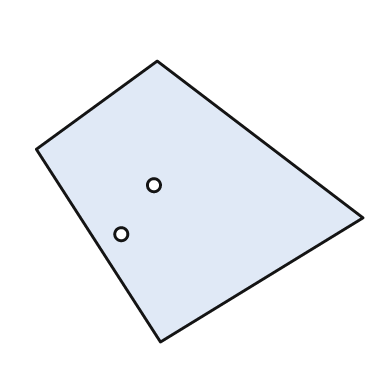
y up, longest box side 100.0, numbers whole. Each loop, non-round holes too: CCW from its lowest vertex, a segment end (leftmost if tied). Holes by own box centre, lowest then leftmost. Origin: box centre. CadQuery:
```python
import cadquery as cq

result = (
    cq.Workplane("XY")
    .moveTo(-12.0, -43.0)
    .lineTo(50.0, -5.0)
    .lineTo(-13.0, 43.0)
    .lineTo(-50.0, 16.0)
    .close()
    .moveTo(-24.0, -10.0)
    .circle(2.0)
    .moveTo(-14.0, 5.0)
    .circle(2.0)
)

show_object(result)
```